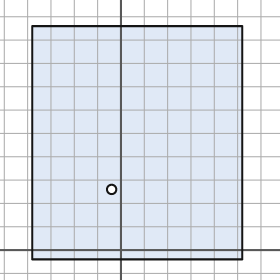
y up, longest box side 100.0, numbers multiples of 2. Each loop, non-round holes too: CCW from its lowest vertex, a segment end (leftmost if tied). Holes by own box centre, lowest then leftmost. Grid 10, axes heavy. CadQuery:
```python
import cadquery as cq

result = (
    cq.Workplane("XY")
    .moveTo(-38.0, -4.0)
    .lineTo(52.0, -4.0)
    .lineTo(52.0, 96.0)
    .lineTo(-38.0, 96.0)
    .close()
    .moveTo(-4.0, 26.0)
    .circle(2.0)
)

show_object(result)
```